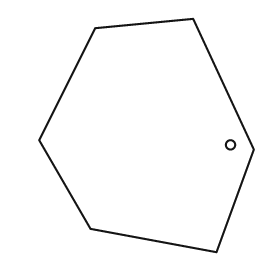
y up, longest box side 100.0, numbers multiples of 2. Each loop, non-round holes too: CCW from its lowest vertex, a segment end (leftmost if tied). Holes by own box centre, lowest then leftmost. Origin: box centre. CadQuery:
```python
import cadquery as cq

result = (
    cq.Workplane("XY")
    .moveTo(30.0, -50.0)
    .lineTo(46.0, -6.0)
    .lineTo(20.0, 50.0)
    .lineTo(-22.0, 46.0)
    .lineTo(-46.0, -2.0)
    .lineTo(-24.0, -40.0)
    .close()
    .moveTo(36.0, -4.0)
    .circle(2.0)
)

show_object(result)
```